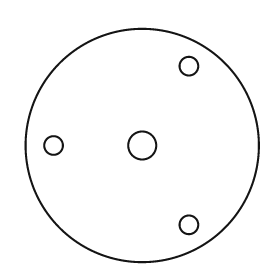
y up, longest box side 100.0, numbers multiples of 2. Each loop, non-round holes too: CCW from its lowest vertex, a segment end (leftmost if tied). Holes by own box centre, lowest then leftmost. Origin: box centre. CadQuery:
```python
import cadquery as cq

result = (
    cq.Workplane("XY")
    .moveTo(0.0, 0.0)
    .circle(50.0)
    .moveTo(20.0, -34.0)
    .circle(4.0)
    .moveTo(-38.0, 0.0)
    .circle(4.0)
    .moveTo(0.0, 0.0)
    .circle(6.0)
    .moveTo(20.0, 34.0)
    .circle(4.0)
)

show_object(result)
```